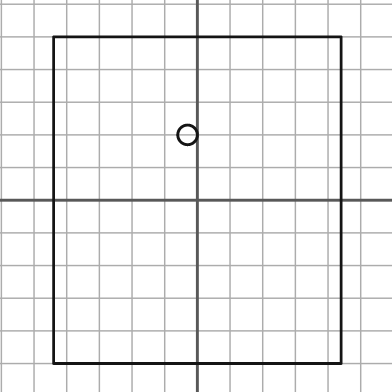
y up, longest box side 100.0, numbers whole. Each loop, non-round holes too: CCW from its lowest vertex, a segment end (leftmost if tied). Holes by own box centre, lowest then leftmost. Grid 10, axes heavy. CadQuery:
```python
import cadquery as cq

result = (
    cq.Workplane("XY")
    .moveTo(-44.0, -50.0)
    .lineTo(44.0, -50.0)
    .lineTo(44.0, 50.0)
    .lineTo(-44.0, 50.0)
    .close()
    .moveTo(-3.0, 20.0)
    .circle(3.0)
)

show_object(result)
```